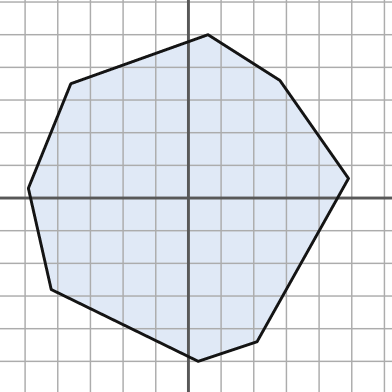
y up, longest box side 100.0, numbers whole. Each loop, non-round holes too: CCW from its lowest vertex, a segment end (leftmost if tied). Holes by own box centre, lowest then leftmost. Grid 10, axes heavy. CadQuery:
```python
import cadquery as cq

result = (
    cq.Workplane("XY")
    .moveTo(3.0, -50.0)
    .lineTo(21.0, -44.0)
    .lineTo(49.0, 6.0)
    .lineTo(28.0, 36.0)
    .lineTo(6.0, 50.0)
    .lineTo(-36.0, 35.0)
    .lineTo(-49.0, 3.0)
    .lineTo(-42.0, -28.0)
    .close()
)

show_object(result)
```